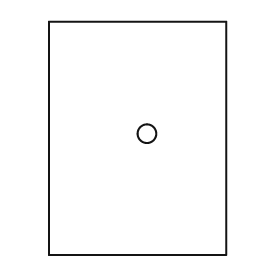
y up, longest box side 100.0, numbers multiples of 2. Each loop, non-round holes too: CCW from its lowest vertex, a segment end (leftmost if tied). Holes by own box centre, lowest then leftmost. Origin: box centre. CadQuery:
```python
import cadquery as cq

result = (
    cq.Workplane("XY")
    .moveTo(-38.0, -50.0)
    .lineTo(38.0, -50.0)
    .lineTo(38.0, 50.0)
    .lineTo(-38.0, 50.0)
    .close()
    .moveTo(4.0, 2.0)
    .circle(4.0)
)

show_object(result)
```